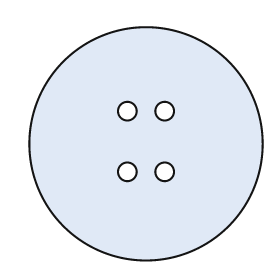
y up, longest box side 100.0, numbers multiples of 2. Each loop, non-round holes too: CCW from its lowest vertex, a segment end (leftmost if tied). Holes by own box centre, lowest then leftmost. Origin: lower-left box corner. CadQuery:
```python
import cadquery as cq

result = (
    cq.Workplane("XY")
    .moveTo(50.0, 50.0)
    .circle(50.0)
    .moveTo(42.0, 38.0)
    .circle(4.0)
    .moveTo(58.0, 38.0)
    .circle(4.0)
    .moveTo(42.0, 64.0)
    .circle(4.0)
    .moveTo(58.0, 64.0)
    .circle(4.0)
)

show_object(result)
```